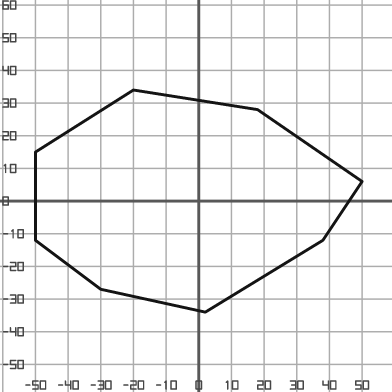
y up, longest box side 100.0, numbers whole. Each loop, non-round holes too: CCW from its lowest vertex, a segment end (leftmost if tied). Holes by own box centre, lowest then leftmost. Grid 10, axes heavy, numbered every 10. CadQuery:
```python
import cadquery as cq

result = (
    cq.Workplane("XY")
    .moveTo(2.0, -34.0)
    .lineTo(38.0, -12.0)
    .lineTo(50.0, 6.0)
    .lineTo(18.0, 28.0)
    .lineTo(-20.0, 34.0)
    .lineTo(-50.0, 15.0)
    .lineTo(-50.0, -12.0)
    .lineTo(-30.0, -27.0)
    .close()
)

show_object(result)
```